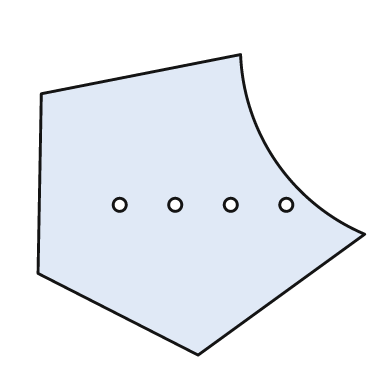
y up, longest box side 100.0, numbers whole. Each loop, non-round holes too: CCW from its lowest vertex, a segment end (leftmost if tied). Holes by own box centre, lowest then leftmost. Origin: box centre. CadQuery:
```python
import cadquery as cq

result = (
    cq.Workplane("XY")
    .moveTo(-1.0, -46.0)
    .lineTo(50.0, -9.0)
    .threePointArc((23.0, 13.0), (12.0, 46.0))
    .lineTo(-49.0, 34.0)
    .lineTo(-50.0, -21.0)
    .close()
    .moveTo(-25.0, 0.0)
    .circle(2.0)
    .moveTo(-8.0, 0.0)
    .circle(2.0)
    .moveTo(9.0, 0.0)
    .circle(2.0)
    .moveTo(26.0, 0.0)
    .circle(2.0)
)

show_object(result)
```